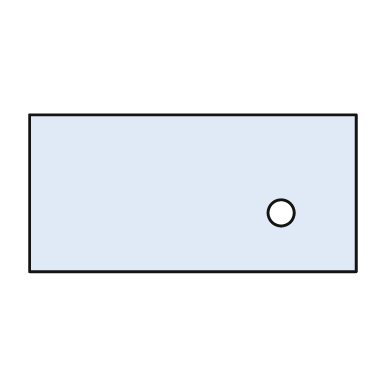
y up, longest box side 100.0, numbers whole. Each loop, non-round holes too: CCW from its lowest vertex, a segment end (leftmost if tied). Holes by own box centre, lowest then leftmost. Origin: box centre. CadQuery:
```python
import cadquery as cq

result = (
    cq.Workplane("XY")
    .moveTo(-50.0, -24.0)
    .lineTo(50.0, -24.0)
    .lineTo(50.0, 24.0)
    .lineTo(-50.0, 24.0)
    .close()
    .moveTo(27.0, -6.0)
    .circle(4.0)
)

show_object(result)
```